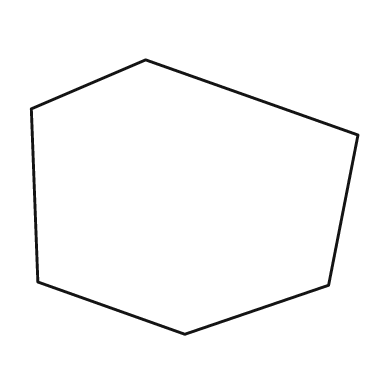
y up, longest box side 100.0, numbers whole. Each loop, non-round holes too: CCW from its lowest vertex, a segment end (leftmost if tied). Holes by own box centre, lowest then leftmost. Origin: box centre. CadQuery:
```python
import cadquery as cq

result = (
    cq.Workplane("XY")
    .moveTo(-3.0, -42.0)
    .lineTo(41.0, -27.0)
    .lineTo(50.0, 19.0)
    .lineTo(-15.0, 42.0)
    .lineTo(-50.0, 27.0)
    .lineTo(-48.0, -26.0)
    .close()
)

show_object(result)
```